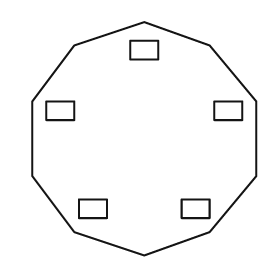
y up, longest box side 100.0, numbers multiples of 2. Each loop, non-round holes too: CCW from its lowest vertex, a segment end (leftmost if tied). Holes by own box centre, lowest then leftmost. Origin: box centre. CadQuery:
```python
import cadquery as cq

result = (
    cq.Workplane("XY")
    .moveTo(0.0, -50.0)
    .lineTo(28.0, -40.0)
    .lineTo(48.0, -16.0)
    .lineTo(48.0, 16.0)
    .lineTo(28.0, 40.0)
    .lineTo(0.0, 50.0)
    .lineTo(-30.0, 40.0)
    .lineTo(-48.0, 16.0)
    .lineTo(-48.0, -16.0)
    .lineTo(-30.0, -40.0)
    .close()
    .moveTo(-28.0, -34.0)
    .lineTo(-16.0, -34.0)
    .lineTo(-16.0, -26.0)
    .lineTo(-28.0, -26.0)
    .close()
    .moveTo(16.0, -34.0)
    .lineTo(28.0, -34.0)
    .lineTo(28.0, -26.0)
    .lineTo(16.0, -26.0)
    .close()
    .moveTo(-42.0, 8.0)
    .lineTo(-30.0, 8.0)
    .lineTo(-30.0, 16.0)
    .lineTo(-42.0, 16.0)
    .close()
    .moveTo(30.0, 8.0)
    .lineTo(42.0, 8.0)
    .lineTo(42.0, 16.0)
    .lineTo(30.0, 16.0)
    .close()
    .moveTo(-6.0, 34.0)
    .lineTo(6.0, 34.0)
    .lineTo(6.0, 42.0)
    .lineTo(-6.0, 42.0)
    .close()
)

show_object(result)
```